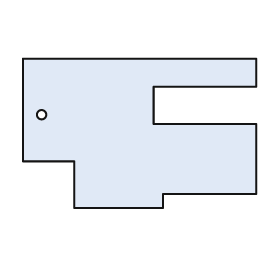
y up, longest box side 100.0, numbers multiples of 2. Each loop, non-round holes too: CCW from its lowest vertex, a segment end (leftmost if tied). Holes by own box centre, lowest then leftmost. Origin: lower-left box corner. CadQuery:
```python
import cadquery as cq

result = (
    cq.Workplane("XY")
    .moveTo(22.0, 0.0)
    .lineTo(60.0, 0.0)
    .lineTo(60.0, 6.0)
    .lineTo(100.0, 6.0)
    .lineTo(100.0, 36.0)
    .lineTo(56.0, 36.0)
    .lineTo(56.0, 52.0)
    .lineTo(100.0, 52.0)
    .lineTo(100.0, 64.0)
    .lineTo(0.0, 64.0)
    .lineTo(0.0, 20.0)
    .lineTo(22.0, 20.0)
    .close()
    .moveTo(8.0, 40.0)
    .circle(2.0)
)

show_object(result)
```